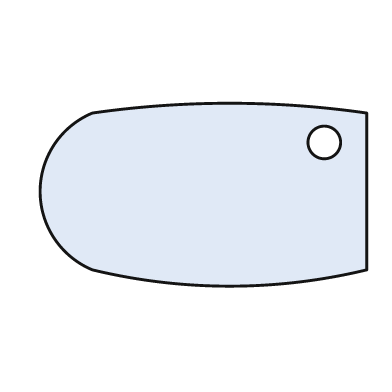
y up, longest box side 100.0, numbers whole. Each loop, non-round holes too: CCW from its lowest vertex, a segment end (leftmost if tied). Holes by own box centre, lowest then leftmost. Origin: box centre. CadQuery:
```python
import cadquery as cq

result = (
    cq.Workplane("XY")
    .moveTo(-34.0, -23.0)
    .threePointArc((8.0, -28.0), (50.0, -23.0))
    .lineTo(50.0, 25.0)
    .threePointArc((8.0, 28.0), (-34.0, 25.0))
    .threePointArc((-50.0, 1.0), (-34.0, -23.0))
    .close()
    .moveTo(37.0, 16.0)
    .circle(5.0)
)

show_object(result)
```